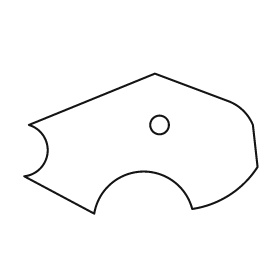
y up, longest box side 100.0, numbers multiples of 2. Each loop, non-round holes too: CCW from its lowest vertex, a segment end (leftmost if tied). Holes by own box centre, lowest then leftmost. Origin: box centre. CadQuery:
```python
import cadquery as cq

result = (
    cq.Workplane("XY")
    .moveTo(-20.0, -30.0)
    .threePointArc((0.0, -12.0), (22.0, -28.0))
    .threePointArc((38.0, -22.0), (50.0, -10.0))
    .lineTo(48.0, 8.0)
    .threePointArc((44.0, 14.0), (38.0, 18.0))
    .lineTo(6.0, 30.0)
    .lineTo(-48.0, 8.0)
    .threePointArc((-40.0, -4.0), (-50.0, -14.0))
    .close()
    .moveTo(8.0, 8.0)
    .circle(4.0)
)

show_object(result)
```